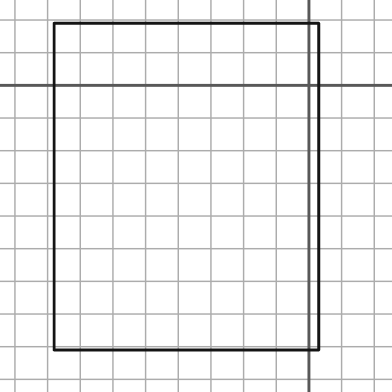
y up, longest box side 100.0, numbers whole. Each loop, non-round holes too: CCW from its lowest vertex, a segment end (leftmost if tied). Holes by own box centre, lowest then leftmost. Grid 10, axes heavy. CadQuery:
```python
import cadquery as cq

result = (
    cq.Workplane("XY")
    .moveTo(-78.0, -81.0)
    .lineTo(3.0, -81.0)
    .lineTo(3.0, 19.0)
    .lineTo(-78.0, 19.0)
    .close()
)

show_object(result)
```